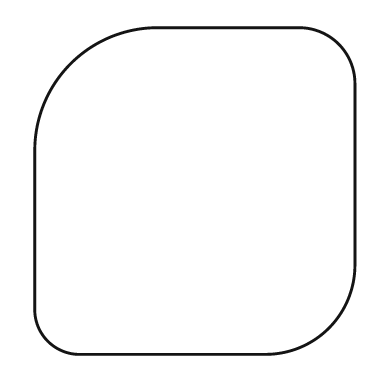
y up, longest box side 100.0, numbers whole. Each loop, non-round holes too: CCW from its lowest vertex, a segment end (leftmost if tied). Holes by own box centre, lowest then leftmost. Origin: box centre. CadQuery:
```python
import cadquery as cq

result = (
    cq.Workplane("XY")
    .moveTo(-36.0, -50.0)
    .lineTo(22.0, -50.0)
    .threePointArc((41.0, -42.0), (49.0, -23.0))
    .lineTo(49.0, 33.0)
    .threePointArc((44.0, 45.0), (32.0, 50.0))
    .lineTo(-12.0, 50.0)
    .threePointArc((-38.0, 39.0), (-49.0, 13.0))
    .lineTo(-49.0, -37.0)
    .threePointArc((-45.0, -46.0), (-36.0, -50.0))
    .close()
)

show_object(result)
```